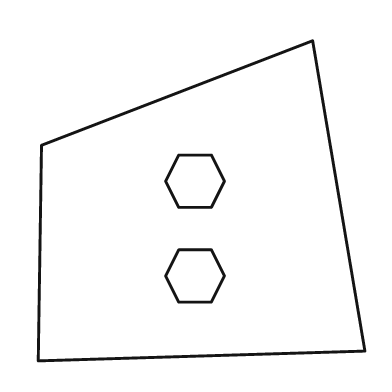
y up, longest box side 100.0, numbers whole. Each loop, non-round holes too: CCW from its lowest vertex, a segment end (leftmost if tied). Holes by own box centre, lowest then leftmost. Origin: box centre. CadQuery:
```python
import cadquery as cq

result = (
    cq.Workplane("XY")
    .moveTo(-50.0, -49.0)
    .lineTo(50.0, -46.0)
    .lineTo(34.0, 49.0)
    .lineTo(-49.0, 17.0)
    .close()
    .moveTo(-7.0, -31.0)
    .lineTo(3.0, -31.0)
    .lineTo(7.0, -23.0)
    .lineTo(3.0, -15.0)
    .lineTo(-7.0, -15.0)
    .lineTo(-11.0, -23.0)
    .close()
    .moveTo(-7.0, -2.0)
    .lineTo(3.0, -2.0)
    .lineTo(7.0, 6.0)
    .lineTo(3.0, 14.0)
    .lineTo(-7.0, 14.0)
    .lineTo(-11.0, 6.0)
    .close()
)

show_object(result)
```